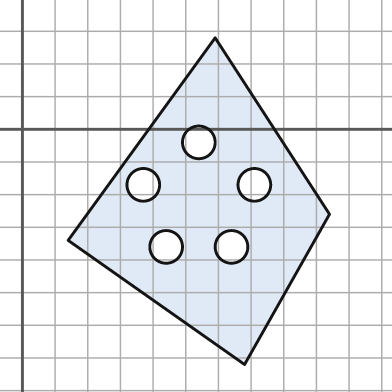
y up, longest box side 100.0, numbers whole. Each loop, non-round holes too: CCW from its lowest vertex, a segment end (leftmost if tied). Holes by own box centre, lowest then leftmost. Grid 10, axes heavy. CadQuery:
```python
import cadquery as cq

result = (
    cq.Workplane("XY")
    .moveTo(68.0, -72.0)
    .lineTo(94.0, -26.0)
    .lineTo(59.0, 28.0)
    .lineTo(14.0, -34.0)
    .close()
    .moveTo(44.0, -36.0)
    .circle(5.0)
    .moveTo(64.0, -36.0)
    .circle(5.0)
    .moveTo(37.0, -17.0)
    .circle(5.0)
    .moveTo(71.0, -17.0)
    .circle(5.0)
    .moveTo(54.0, -4.0)
    .circle(5.0)
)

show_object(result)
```